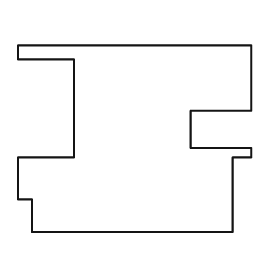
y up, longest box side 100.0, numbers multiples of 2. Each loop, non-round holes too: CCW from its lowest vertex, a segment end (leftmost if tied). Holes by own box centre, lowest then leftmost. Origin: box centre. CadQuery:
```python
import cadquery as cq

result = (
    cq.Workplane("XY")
    .moveTo(-44.0, -40.0)
    .lineTo(42.0, -40.0)
    .lineTo(42.0, -8.0)
    .lineTo(50.0, -8.0)
    .lineTo(50.0, -4.0)
    .lineTo(24.0, -4.0)
    .lineTo(24.0, 12.0)
    .lineTo(50.0, 12.0)
    .lineTo(50.0, 40.0)
    .lineTo(-50.0, 40.0)
    .lineTo(-50.0, 34.0)
    .lineTo(-26.0, 34.0)
    .lineTo(-26.0, -8.0)
    .lineTo(-50.0, -8.0)
    .lineTo(-50.0, -26.0)
    .lineTo(-44.0, -26.0)
    .close()
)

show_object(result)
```